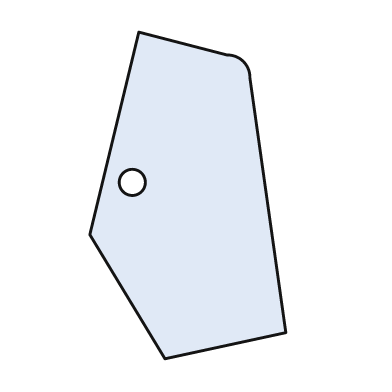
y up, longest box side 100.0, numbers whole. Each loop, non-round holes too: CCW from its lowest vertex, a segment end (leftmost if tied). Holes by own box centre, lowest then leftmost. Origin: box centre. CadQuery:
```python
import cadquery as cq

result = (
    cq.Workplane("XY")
    .moveTo(-7.0, -50.0)
    .lineTo(30.0, -42.0)
    .lineTo(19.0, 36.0)
    .threePointArc((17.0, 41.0), (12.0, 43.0))
    .lineTo(-15.0, 50.0)
    .lineTo(-30.0, -12.0)
    .close()
    .moveTo(-17.0, 4.0)
    .circle(4.0)
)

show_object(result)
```